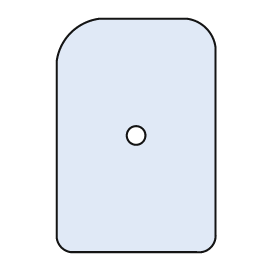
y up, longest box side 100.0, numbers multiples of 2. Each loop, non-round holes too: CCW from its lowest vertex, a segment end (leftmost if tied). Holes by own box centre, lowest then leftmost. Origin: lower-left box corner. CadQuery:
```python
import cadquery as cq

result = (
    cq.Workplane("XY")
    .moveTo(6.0, 0.0)
    .lineTo(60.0, 0.0)
    .threePointArc((66.0, 2.0), (68.0, 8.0))
    .lineTo(68.0, 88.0)
    .threePointArc((64.0, 96.0), (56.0, 100.0))
    .lineTo(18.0, 100.0)
    .threePointArc((6.0, 94.0), (0.0, 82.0))
    .lineTo(0.0, 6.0)
    .threePointArc((2.0, 2.0), (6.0, 0.0))
    .close()
    .moveTo(34.0, 50.0)
    .circle(4.0)
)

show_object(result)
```